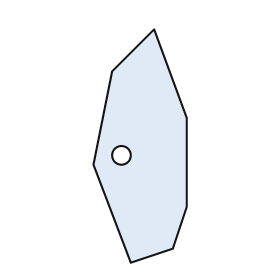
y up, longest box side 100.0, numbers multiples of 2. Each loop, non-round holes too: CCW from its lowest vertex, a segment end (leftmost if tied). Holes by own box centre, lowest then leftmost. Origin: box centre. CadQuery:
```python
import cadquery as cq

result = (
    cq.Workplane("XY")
    .moveTo(-4.0, -50.0)
    .lineTo(14.0, -44.0)
    .lineTo(20.0, -26.0)
    .lineTo(20.0, 12.0)
    .lineTo(6.0, 50.0)
    .lineTo(-12.0, 32.0)
    .lineTo(-20.0, -8.0)
    .close()
    .moveTo(-8.0, -4.0)
    .circle(4.0)
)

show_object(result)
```